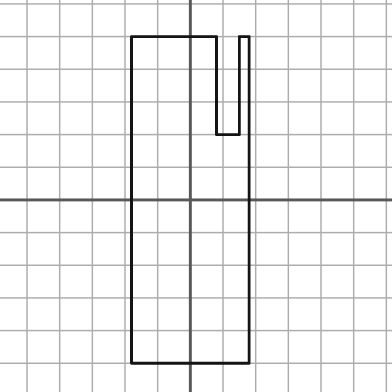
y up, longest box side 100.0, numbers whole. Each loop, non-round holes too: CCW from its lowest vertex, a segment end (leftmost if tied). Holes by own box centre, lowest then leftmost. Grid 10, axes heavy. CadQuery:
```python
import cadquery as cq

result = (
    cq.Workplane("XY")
    .moveTo(-18.0, -50.0)
    .lineTo(18.0, -50.0)
    .lineTo(18.0, 50.0)
    .lineTo(15.0, 50.0)
    .lineTo(15.0, 20.0)
    .lineTo(8.0, 20.0)
    .lineTo(8.0, 50.0)
    .lineTo(-18.0, 50.0)
    .close()
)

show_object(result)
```